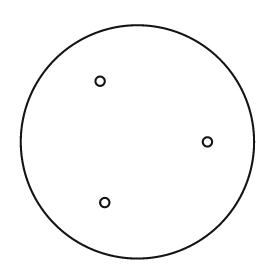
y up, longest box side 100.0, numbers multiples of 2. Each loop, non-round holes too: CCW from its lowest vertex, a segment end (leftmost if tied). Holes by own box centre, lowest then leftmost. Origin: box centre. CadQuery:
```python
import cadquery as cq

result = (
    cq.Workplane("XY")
    .moveTo(0.0, 0.0)
    .circle(50.0)
    .moveTo(-14.0, -26.0)
    .circle(2.0)
    .moveTo(30.0, 0.0)
    .circle(2.0)
    .moveTo(-16.0, 26.0)
    .circle(2.0)
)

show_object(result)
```